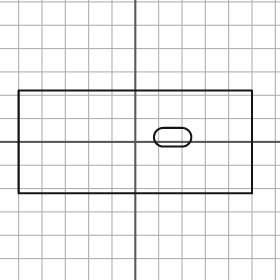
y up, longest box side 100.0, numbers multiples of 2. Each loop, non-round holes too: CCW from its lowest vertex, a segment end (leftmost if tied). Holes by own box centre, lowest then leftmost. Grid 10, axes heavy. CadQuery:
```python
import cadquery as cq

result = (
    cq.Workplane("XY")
    .moveTo(-50.0, -22.0)
    .lineTo(50.0, -22.0)
    .lineTo(50.0, 22.0)
    .lineTo(-50.0, 22.0)
    .close()
    .moveTo(12.0, -2.0)
    .lineTo(20.0, -2.0)
    .threePointArc((24.0, 2.0), (20.0, 6.0))
    .lineTo(12.0, 6.0)
    .threePointArc((8.0, 2.0), (12.0, -2.0))
    .close()
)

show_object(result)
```